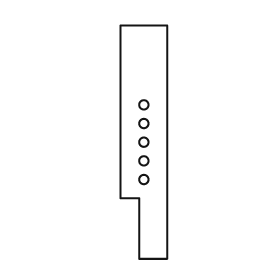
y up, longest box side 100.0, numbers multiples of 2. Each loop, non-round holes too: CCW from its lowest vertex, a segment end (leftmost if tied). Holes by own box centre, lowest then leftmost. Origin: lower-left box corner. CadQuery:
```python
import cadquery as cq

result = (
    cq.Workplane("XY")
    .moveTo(8.0, 0.0)
    .lineTo(20.0, 0.0)
    .lineTo(20.0, 100.0)
    .lineTo(0.0, 100.0)
    .lineTo(0.0, 26.0)
    .lineTo(8.0, 26.0)
    .close()
    .moveTo(10.0, 34.0)
    .circle(2.0)
    .moveTo(10.0, 42.0)
    .circle(2.0)
    .moveTo(10.0, 50.0)
    .circle(2.0)
    .moveTo(10.0, 58.0)
    .circle(2.0)
    .moveTo(10.0, 66.0)
    .circle(2.0)
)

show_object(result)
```